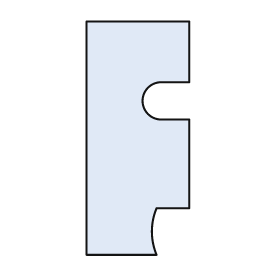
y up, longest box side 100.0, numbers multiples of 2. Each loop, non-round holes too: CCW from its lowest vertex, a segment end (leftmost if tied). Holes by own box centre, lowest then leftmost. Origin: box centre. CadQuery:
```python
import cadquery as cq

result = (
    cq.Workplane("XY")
    .moveTo(-22.0, -50.0)
    .lineTo(8.0, -50.0)
    .threePointArc((6.0, -40.0), (8.0, -30.0))
    .lineTo(22.0, -30.0)
    .lineTo(22.0, 8.0)
    .lineTo(10.0, 8.0)
    .threePointArc((2.0, 16.0), (10.0, 24.0))
    .lineTo(22.0, 24.0)
    .lineTo(22.0, 50.0)
    .lineTo(-22.0, 50.0)
    .close()
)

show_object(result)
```